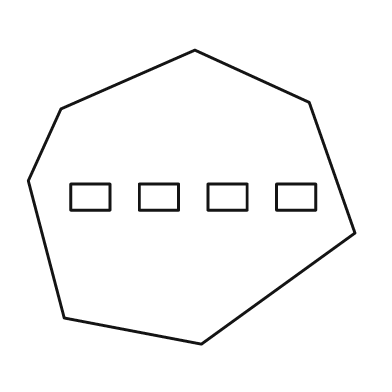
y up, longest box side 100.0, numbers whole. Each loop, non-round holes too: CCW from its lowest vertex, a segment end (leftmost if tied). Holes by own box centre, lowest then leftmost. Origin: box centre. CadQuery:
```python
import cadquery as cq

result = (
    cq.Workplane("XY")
    .moveTo(3.0, -45.0)
    .lineTo(50.0, -11.0)
    .lineTo(36.0, 29.0)
    .lineTo(1.0, 45.0)
    .lineTo(-40.0, 27.0)
    .lineTo(-50.0, 5.0)
    .lineTo(-39.0, -37.0)
    .close()
    .moveTo(-37.0, -4.0)
    .lineTo(-25.0, -4.0)
    .lineTo(-25.0, 4.0)
    .lineTo(-37.0, 4.0)
    .close()
    .moveTo(-16.0, -4.0)
    .lineTo(-4.0, -4.0)
    .lineTo(-4.0, 4.0)
    .lineTo(-16.0, 4.0)
    .close()
    .moveTo(5.0, -4.0)
    .lineTo(17.0, -4.0)
    .lineTo(17.0, 4.0)
    .lineTo(5.0, 4.0)
    .close()
    .moveTo(26.0, -4.0)
    .lineTo(38.0, -4.0)
    .lineTo(38.0, 4.0)
    .lineTo(26.0, 4.0)
    .close()
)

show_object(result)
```